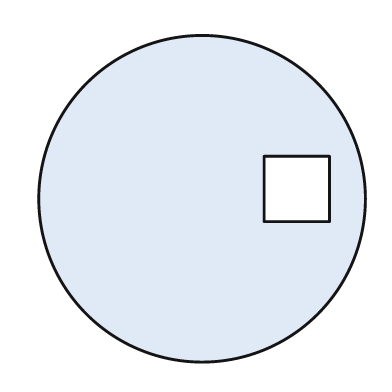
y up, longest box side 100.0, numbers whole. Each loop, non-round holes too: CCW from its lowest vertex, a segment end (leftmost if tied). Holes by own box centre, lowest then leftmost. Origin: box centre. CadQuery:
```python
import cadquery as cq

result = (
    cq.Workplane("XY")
    .moveTo(0.0, 0.0)
    .circle(50.0)
    .moveTo(19.0, -7.0)
    .lineTo(39.0, -7.0)
    .lineTo(39.0, 13.0)
    .lineTo(19.0, 13.0)
    .close()
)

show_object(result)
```